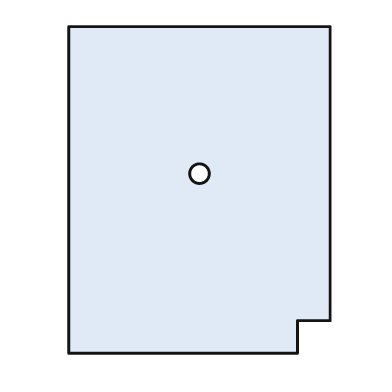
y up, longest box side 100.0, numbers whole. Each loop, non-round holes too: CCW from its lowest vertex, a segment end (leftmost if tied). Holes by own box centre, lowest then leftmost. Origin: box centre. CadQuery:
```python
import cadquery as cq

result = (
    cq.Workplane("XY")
    .moveTo(-40.0, -50.0)
    .lineTo(30.0, -50.0)
    .lineTo(30.0, -40.0)
    .lineTo(40.0, -40.0)
    .lineTo(40.0, 50.0)
    .lineTo(-40.0, 50.0)
    .close()
    .moveTo(0.0, 5.0)
    .circle(3.0)
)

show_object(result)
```